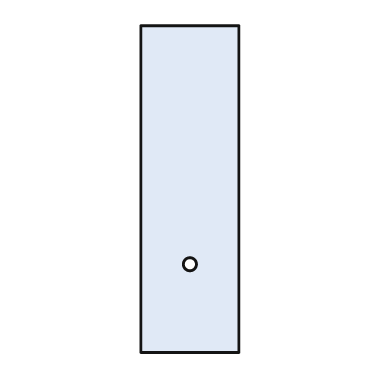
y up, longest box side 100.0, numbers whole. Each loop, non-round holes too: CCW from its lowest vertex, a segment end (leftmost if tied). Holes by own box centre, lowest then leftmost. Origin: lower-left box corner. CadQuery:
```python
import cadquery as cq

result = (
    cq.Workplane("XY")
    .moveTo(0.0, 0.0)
    .lineTo(30.0, 0.0)
    .lineTo(30.0, 100.0)
    .lineTo(0.0, 100.0)
    .close()
    .moveTo(15.0, 27.0)
    .circle(2.0)
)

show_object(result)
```